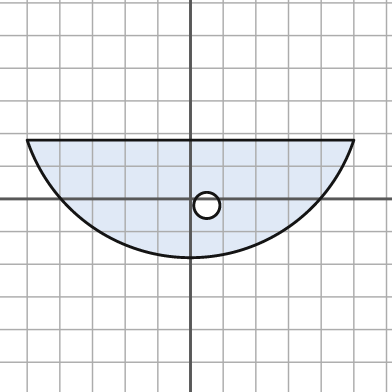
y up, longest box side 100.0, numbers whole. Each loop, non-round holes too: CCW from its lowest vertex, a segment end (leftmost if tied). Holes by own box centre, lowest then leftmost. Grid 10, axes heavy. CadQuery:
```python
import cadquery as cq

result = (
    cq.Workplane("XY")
    .moveTo(-50.0, 18.0)
    .threePointArc((0.0, -18.0), (50.0, 18.0))
    .close()
    .moveTo(5.0, -2.0)
    .circle(4.0)
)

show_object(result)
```